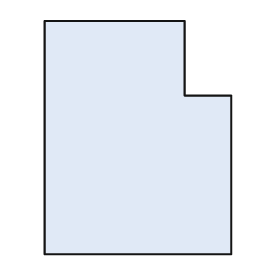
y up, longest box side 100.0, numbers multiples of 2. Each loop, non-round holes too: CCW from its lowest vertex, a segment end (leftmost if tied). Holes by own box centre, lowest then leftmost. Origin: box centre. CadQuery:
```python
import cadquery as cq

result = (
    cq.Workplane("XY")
    .moveTo(-40.0, -50.0)
    .lineTo(40.0, -50.0)
    .lineTo(40.0, 18.0)
    .lineTo(20.0, 18.0)
    .lineTo(20.0, 50.0)
    .lineTo(-40.0, 50.0)
    .close()
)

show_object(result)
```